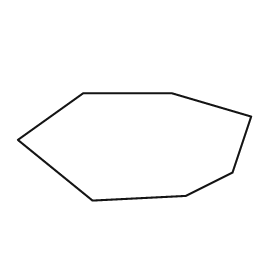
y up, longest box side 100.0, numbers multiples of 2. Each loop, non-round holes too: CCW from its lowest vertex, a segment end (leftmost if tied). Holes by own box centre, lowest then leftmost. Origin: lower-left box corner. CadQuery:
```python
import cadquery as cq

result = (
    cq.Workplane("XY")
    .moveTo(32.0, 0.0)
    .lineTo(72.0, 2.0)
    .lineTo(92.0, 12.0)
    .lineTo(100.0, 36.0)
    .lineTo(66.0, 46.0)
    .lineTo(28.0, 46.0)
    .lineTo(0.0, 26.0)
    .close()
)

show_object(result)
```